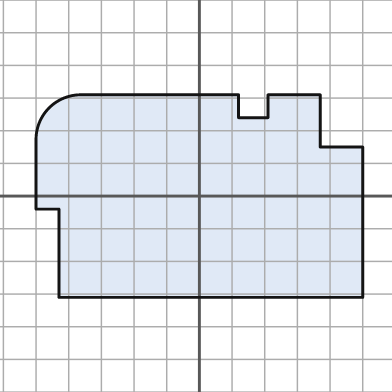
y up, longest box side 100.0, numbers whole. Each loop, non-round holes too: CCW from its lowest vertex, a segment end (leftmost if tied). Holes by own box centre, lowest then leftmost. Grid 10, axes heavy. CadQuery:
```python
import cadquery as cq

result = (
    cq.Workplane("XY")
    .moveTo(-43.0, -31.0)
    .lineTo(50.0, -31.0)
    .lineTo(50.0, 15.0)
    .lineTo(37.0, 15.0)
    .lineTo(37.0, 31.0)
    .lineTo(21.0, 31.0)
    .lineTo(21.0, 24.0)
    .lineTo(12.0, 24.0)
    .lineTo(12.0, 31.0)
    .lineTo(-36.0, 31.0)
    .threePointArc((-46.0, 27.0), (-50.0, 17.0))
    .lineTo(-50.0, -4.0)
    .lineTo(-43.0, -4.0)
    .close()
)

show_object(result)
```